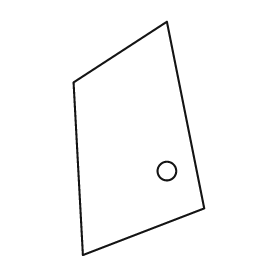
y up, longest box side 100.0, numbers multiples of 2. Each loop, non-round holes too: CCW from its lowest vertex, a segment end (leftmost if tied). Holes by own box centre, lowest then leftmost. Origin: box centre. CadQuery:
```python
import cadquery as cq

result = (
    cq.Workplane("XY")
    .moveTo(-24.0, -50.0)
    .lineTo(28.0, -30.0)
    .lineTo(12.0, 50.0)
    .lineTo(-28.0, 24.0)
    .close()
    .moveTo(12.0, -14.0)
    .circle(4.0)
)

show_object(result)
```